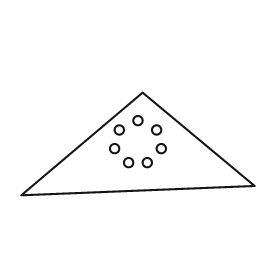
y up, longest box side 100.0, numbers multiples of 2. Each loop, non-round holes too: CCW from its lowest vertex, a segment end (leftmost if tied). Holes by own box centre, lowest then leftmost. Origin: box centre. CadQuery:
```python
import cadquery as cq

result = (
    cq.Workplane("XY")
    .moveTo(-50.0, -22.0)
    .lineTo(50.0, -18.0)
    .lineTo(2.0, 22.0)
    .close()
    .moveTo(-4.0, -8.0)
    .circle(2.0)
    .moveTo(4.0, -8.0)
    .circle(2.0)
    .moveTo(-10.0, -2.0)
    .circle(2.0)
    .moveTo(10.0, -2.0)
    .circle(2.0)
    .moveTo(-8.0, 6.0)
    .circle(2.0)
    .moveTo(8.0, 6.0)
    .circle(2.0)
    .moveTo(0.0, 10.0)
    .circle(2.0)
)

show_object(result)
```